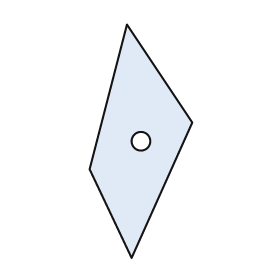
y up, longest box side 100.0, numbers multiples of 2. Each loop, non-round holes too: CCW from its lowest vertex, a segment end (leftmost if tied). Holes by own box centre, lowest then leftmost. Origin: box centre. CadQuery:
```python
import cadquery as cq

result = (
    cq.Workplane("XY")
    .moveTo(-4.0, -50.0)
    .lineTo(22.0, 8.0)
    .lineTo(-6.0, 50.0)
    .lineTo(-22.0, -12.0)
    .close()
    .moveTo(0.0, 0.0)
    .circle(4.0)
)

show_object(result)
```